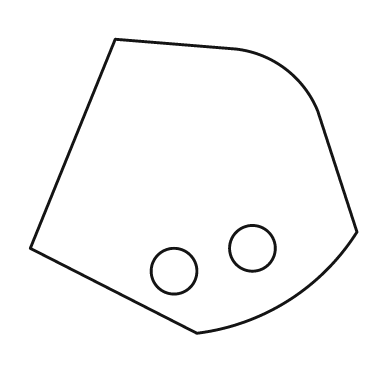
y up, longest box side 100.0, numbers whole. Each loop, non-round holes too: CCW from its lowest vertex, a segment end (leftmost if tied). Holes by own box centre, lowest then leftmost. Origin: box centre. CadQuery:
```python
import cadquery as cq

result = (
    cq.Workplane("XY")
    .moveTo(1.0, -45.0)
    .threePointArc((29.0, -35.0), (50.0, -14.0))
    .lineTo(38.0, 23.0)
    .threePointArc((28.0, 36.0), (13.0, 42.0))
    .lineTo(-24.0, 45.0)
    .lineTo(-50.0, -19.0)
    .close()
    .moveTo(-6.0, -26.0)
    .circle(7.0)
    .moveTo(18.0, -19.0)
    .circle(7.0)
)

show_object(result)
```